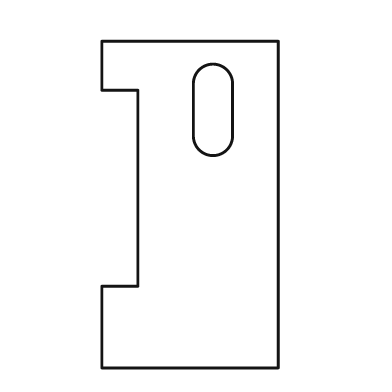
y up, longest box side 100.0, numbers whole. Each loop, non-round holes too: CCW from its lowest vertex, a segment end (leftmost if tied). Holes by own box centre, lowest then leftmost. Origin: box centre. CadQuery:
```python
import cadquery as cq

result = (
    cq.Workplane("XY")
    .moveTo(-27.0, -50.0)
    .lineTo(27.0, -50.0)
    .lineTo(27.0, 50.0)
    .lineTo(-27.0, 50.0)
    .lineTo(-27.0, 35.0)
    .lineTo(-16.0, 35.0)
    .lineTo(-16.0, -25.0)
    .lineTo(-27.0, -25.0)
    .close()
    .moveTo(1.0, 21.0)
    .threePointArc((7.0, 15.0), (13.0, 21.0))
    .lineTo(13.0, 37.0)
    .threePointArc((7.0, 43.0), (1.0, 37.0))
    .close()
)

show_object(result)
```